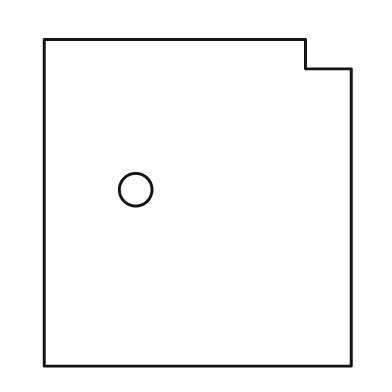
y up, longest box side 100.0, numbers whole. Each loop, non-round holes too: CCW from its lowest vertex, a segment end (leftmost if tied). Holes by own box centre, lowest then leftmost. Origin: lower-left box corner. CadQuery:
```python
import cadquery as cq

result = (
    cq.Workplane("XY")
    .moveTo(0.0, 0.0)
    .lineTo(94.0, 0.0)
    .lineTo(94.0, 91.0)
    .lineTo(80.0, 91.0)
    .lineTo(80.0, 100.0)
    .lineTo(0.0, 100.0)
    .close()
    .moveTo(28.0, 54.0)
    .circle(5.0)
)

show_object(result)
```